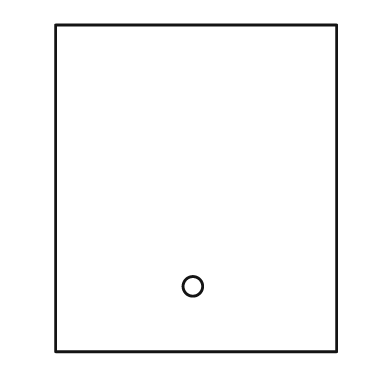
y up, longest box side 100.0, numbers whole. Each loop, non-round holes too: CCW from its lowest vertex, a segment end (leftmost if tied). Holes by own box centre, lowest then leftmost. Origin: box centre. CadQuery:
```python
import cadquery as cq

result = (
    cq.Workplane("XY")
    .moveTo(-43.0, -50.0)
    .lineTo(43.0, -50.0)
    .lineTo(43.0, 50.0)
    .lineTo(-43.0, 50.0)
    .close()
    .moveTo(-1.0, -30.0)
    .circle(3.0)
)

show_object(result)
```